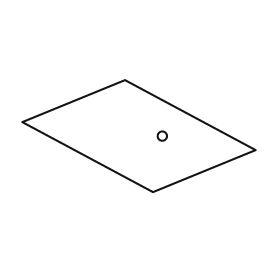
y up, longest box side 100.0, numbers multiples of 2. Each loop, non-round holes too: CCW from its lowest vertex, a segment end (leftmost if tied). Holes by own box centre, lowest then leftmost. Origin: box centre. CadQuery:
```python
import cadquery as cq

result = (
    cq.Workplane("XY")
    .moveTo(6.0, -24.0)
    .lineTo(50.0, -6.0)
    .lineTo(-6.0, 24.0)
    .lineTo(-50.0, 6.0)
    .close()
    .moveTo(10.0, 0.0)
    .circle(2.0)
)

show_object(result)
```